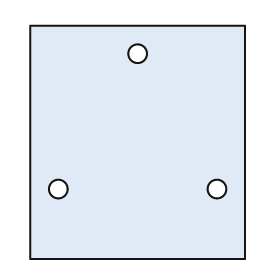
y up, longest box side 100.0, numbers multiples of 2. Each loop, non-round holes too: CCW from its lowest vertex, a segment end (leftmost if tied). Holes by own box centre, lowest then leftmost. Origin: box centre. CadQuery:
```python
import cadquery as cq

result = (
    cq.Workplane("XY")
    .moveTo(-46.0, -50.0)
    .lineTo(46.0, -50.0)
    .lineTo(46.0, 50.0)
    .lineTo(-46.0, 50.0)
    .close()
    .moveTo(-34.0, -20.0)
    .circle(4.0)
    .moveTo(34.0, -20.0)
    .circle(4.0)
    .moveTo(0.0, 38.0)
    .circle(4.0)
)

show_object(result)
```